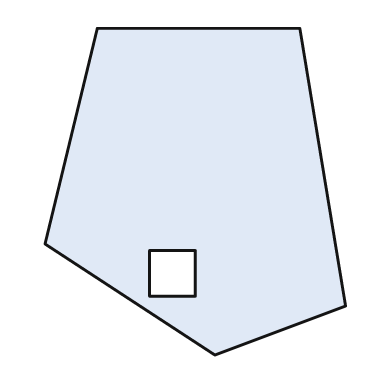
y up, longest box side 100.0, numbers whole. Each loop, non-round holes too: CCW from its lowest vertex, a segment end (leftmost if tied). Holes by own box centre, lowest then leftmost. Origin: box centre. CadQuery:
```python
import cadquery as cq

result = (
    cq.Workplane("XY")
    .moveTo(6.0, -50.0)
    .lineTo(46.0, -35.0)
    .lineTo(32.0, 50.0)
    .lineTo(-30.0, 50.0)
    .lineTo(-46.0, -16.0)
    .close()
    .moveTo(-14.0, -32.0)
    .lineTo(0.0, -32.0)
    .lineTo(0.0, -18.0)
    .lineTo(-14.0, -18.0)
    .close()
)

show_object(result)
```